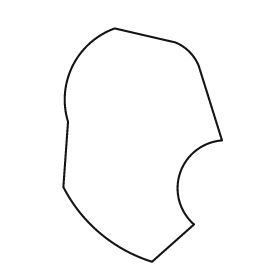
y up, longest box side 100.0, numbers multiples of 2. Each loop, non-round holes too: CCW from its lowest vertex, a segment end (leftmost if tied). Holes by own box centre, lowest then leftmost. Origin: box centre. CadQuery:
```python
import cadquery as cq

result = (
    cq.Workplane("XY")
    .moveTo(4.0, -50.0)
    .lineTo(22.0, -34.0)
    .threePointArc((16.0, -12.0), (34.0, 2.0))
    .lineTo(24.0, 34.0)
    .threePointArc((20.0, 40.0), (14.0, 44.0))
    .lineTo(-12.0, 50.0)
    .threePointArc((-30.0, 34.0), (-32.0, 10.0))
    .lineTo(-34.0, -18.0)
    .threePointArc((-18.0, -38.0), (4.0, -50.0))
    .close()
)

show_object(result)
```